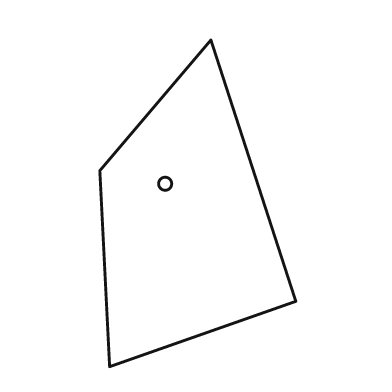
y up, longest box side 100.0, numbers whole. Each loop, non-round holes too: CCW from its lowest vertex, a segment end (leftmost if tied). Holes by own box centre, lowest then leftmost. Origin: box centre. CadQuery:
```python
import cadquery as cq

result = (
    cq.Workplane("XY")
    .moveTo(-27.0, -50.0)
    .lineTo(30.0, -30.0)
    .lineTo(4.0, 50.0)
    .lineTo(-30.0, 10.0)
    .close()
    .moveTo(-10.0, 6.0)
    .circle(2.0)
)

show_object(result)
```